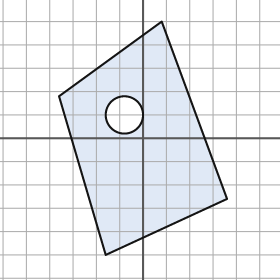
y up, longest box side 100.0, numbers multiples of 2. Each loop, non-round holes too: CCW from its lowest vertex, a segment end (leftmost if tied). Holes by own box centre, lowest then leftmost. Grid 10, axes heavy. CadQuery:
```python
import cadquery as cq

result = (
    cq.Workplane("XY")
    .moveTo(-16.0, -50.0)
    .lineTo(36.0, -26.0)
    .lineTo(8.0, 50.0)
    .lineTo(-36.0, 18.0)
    .close()
    .moveTo(-8.0, 10.0)
    .circle(8.0)
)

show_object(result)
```